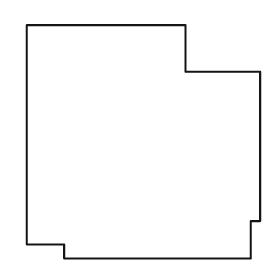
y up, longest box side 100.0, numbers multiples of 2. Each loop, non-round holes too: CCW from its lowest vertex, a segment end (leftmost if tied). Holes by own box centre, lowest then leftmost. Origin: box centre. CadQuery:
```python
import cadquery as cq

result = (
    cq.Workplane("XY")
    .moveTo(-34.0, -50.0)
    .lineTo(46.0, -50.0)
    .lineTo(46.0, -34.0)
    .lineTo(50.0, -34.0)
    .lineTo(50.0, 30.0)
    .lineTo(18.0, 30.0)
    .lineTo(18.0, 50.0)
    .lineTo(-50.0, 50.0)
    .lineTo(-50.0, -44.0)
    .lineTo(-34.0, -44.0)
    .close()
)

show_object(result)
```